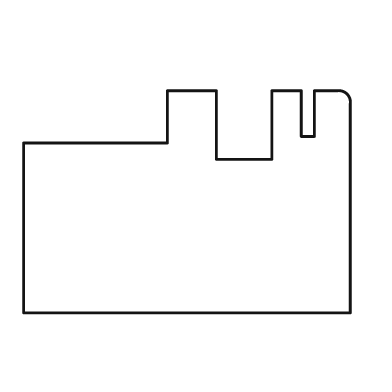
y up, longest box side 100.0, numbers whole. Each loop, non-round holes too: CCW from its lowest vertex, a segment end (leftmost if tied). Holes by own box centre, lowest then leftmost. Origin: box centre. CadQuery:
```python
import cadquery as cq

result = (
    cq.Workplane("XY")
    .moveTo(-50.0, -34.0)
    .lineTo(50.0, -34.0)
    .lineTo(50.0, 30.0)
    .threePointArc((49.0, 33.0), (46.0, 34.0))
    .lineTo(39.0, 34.0)
    .lineTo(39.0, 20.0)
    .lineTo(35.0, 20.0)
    .lineTo(35.0, 34.0)
    .lineTo(26.0, 34.0)
    .lineTo(26.0, 13.0)
    .lineTo(9.0, 13.0)
    .lineTo(9.0, 34.0)
    .lineTo(-6.0, 34.0)
    .lineTo(-6.0, 18.0)
    .lineTo(-50.0, 18.0)
    .close()
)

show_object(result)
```